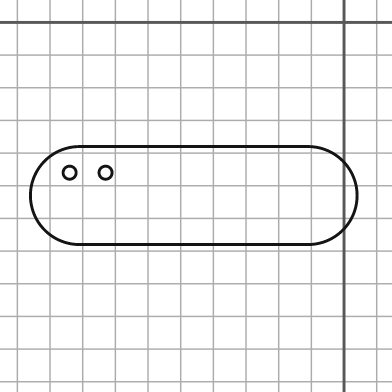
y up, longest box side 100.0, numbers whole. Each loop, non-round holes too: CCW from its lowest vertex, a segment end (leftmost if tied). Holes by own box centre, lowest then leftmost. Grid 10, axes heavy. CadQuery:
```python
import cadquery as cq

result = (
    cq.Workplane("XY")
    .moveTo(-81.0, -68.0)
    .lineTo(-11.0, -68.0)
    .threePointArc((4.0, -53.0), (-11.0, -38.0))
    .lineTo(-81.0, -38.0)
    .threePointArc((-96.0, -53.0), (-81.0, -68.0))
    .close()
    .moveTo(-84.0, -46.0)
    .circle(2.0)
    .moveTo(-73.0, -46.0)
    .circle(2.0)
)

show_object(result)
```